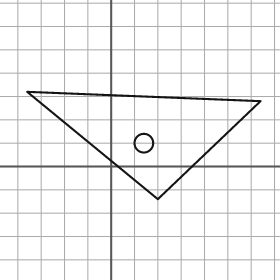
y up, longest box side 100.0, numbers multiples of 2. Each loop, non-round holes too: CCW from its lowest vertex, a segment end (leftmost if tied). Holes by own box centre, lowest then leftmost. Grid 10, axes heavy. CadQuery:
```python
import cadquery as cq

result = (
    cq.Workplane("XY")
    .moveTo(20.0, -14.0)
    .lineTo(64.0, 28.0)
    .lineTo(-36.0, 32.0)
    .close()
    .moveTo(14.0, 10.0)
    .circle(4.0)
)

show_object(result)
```